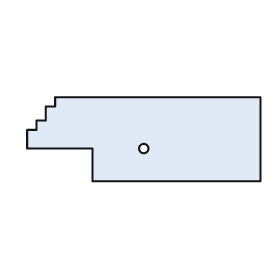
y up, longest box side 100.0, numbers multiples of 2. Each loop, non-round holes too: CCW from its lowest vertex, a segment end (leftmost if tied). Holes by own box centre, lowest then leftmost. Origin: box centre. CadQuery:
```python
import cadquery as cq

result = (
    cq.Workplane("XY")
    .moveTo(-22.0, -18.0)
    .lineTo(50.0, -18.0)
    .lineTo(50.0, 18.0)
    .lineTo(-38.0, 18.0)
    .lineTo(-38.0, 14.0)
    .lineTo(-42.0, 14.0)
    .lineTo(-42.0, 8.0)
    .lineTo(-46.0, 8.0)
    .lineTo(-46.0, 4.0)
    .lineTo(-50.0, 4.0)
    .lineTo(-50.0, -4.0)
    .lineTo(-22.0, -4.0)
    .close()
    .moveTo(0.0, -4.0)
    .circle(2.0)
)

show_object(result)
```